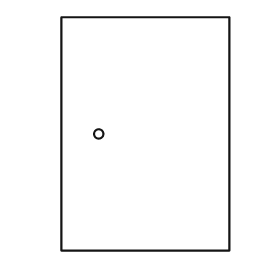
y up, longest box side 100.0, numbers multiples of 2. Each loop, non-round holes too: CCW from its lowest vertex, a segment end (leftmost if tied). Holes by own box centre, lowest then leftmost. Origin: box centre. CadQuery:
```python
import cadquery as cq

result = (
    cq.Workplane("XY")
    .moveTo(-36.0, -50.0)
    .lineTo(36.0, -50.0)
    .lineTo(36.0, 50.0)
    .lineTo(-36.0, 50.0)
    .close()
    .moveTo(-20.0, 0.0)
    .circle(2.0)
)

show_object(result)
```